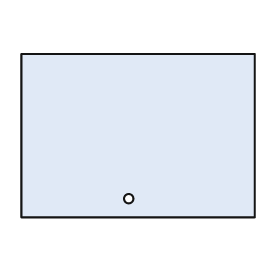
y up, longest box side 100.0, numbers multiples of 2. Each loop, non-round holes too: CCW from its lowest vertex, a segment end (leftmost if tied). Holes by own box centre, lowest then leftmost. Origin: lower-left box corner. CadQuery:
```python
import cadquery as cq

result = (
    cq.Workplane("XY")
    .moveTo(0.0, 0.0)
    .lineTo(100.0, 0.0)
    .lineTo(100.0, 70.0)
    .lineTo(0.0, 70.0)
    .close()
    .moveTo(46.0, 8.0)
    .circle(2.0)
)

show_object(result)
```